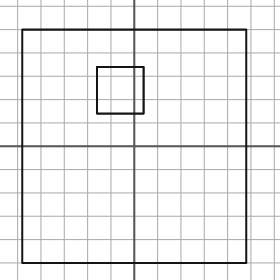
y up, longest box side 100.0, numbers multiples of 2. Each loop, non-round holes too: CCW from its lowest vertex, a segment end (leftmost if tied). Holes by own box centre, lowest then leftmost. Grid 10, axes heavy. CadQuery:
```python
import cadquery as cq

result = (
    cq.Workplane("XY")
    .moveTo(-48.0, -50.0)
    .lineTo(48.0, -50.0)
    .lineTo(48.0, 50.0)
    .lineTo(-48.0, 50.0)
    .close()
    .moveTo(-16.0, 14.0)
    .lineTo(4.0, 14.0)
    .lineTo(4.0, 34.0)
    .lineTo(-16.0, 34.0)
    .close()
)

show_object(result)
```